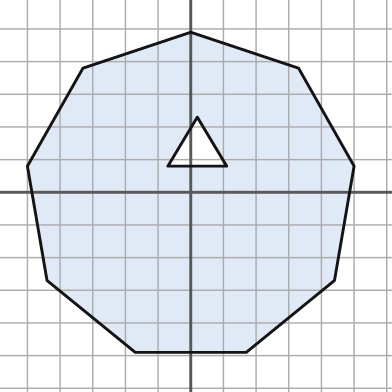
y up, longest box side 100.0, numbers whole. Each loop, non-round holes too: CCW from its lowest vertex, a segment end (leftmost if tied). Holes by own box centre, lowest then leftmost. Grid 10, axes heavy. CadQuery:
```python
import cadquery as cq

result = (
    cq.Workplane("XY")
    .moveTo(-17.0, -49.0)
    .lineTo(17.0, -49.0)
    .lineTo(44.0, -27.0)
    .lineTo(50.0, 8.0)
    .lineTo(33.0, 38.0)
    .lineTo(0.0, 49.0)
    .lineTo(-33.0, 38.0)
    .lineTo(-50.0, 8.0)
    .lineTo(-44.0, -27.0)
    .close()
    .moveTo(-7.0, 8.0)
    .lineTo(11.0, 8.0)
    .lineTo(2.0, 23.0)
    .close()
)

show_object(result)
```